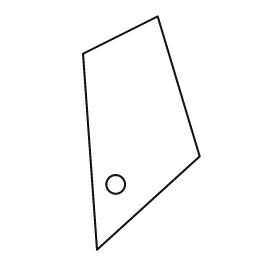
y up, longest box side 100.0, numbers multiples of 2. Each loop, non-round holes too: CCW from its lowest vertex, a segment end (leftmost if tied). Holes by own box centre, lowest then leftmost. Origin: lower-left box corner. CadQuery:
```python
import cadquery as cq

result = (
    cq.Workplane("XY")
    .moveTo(6.0, 0.0)
    .lineTo(50.0, 40.0)
    .lineTo(32.0, 100.0)
    .lineTo(0.0, 84.0)
    .close()
    .moveTo(14.0, 28.0)
    .circle(4.0)
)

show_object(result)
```